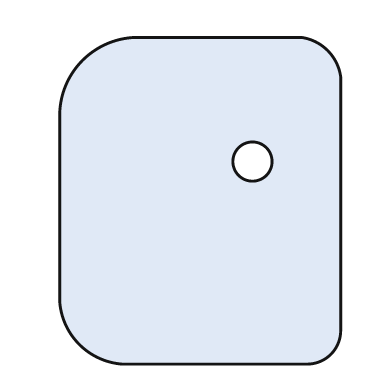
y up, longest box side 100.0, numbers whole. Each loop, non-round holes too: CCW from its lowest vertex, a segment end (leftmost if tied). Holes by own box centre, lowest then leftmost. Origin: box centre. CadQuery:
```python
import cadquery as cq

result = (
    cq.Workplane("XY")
    .moveTo(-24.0, -50.0)
    .lineTo(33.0, -50.0)
    .threePointArc((40.0, -47.0), (43.0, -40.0))
    .lineTo(43.0, 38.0)
    .threePointArc((39.0, 46.0), (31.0, 50.0))
    .lineTo(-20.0, 50.0)
    .threePointArc((-36.0, 43.0), (-43.0, 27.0))
    .lineTo(-43.0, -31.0)
    .threePointArc((-37.0, -44.0), (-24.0, -50.0))
    .close()
    .moveTo(16.0, 12.0)
    .circle(6.0)
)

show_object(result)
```